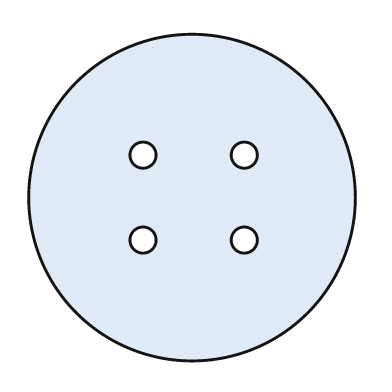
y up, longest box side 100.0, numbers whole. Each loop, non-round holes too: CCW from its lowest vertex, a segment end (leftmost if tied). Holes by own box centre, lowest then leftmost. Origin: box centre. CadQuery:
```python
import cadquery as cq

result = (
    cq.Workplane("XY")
    .moveTo(0.0, 0.0)
    .circle(50.0)
    .moveTo(-15.0, -13.0)
    .circle(4.0)
    .moveTo(16.0, -13.0)
    .circle(4.0)
    .moveTo(-15.0, 13.0)
    .circle(4.0)
    .moveTo(16.0, 13.0)
    .circle(4.0)
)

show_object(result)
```